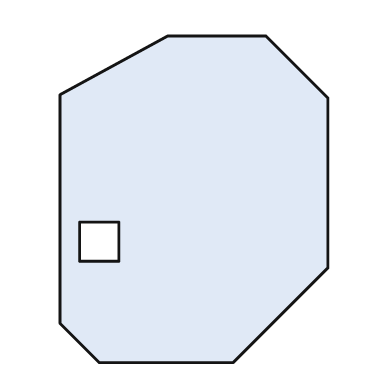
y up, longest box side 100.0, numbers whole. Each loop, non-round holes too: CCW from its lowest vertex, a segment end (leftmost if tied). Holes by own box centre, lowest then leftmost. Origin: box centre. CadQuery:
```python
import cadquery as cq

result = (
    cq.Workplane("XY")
    .moveTo(-29.0, -50.0)
    .lineTo(12.0, -50.0)
    .lineTo(41.0, -21.0)
    .lineTo(41.0, 31.0)
    .lineTo(22.0, 50.0)
    .lineTo(-8.0, 50.0)
    .lineTo(-41.0, 32.0)
    .lineTo(-41.0, -38.0)
    .close()
    .moveTo(-35.0, -19.0)
    .lineTo(-23.0, -19.0)
    .lineTo(-23.0, -7.0)
    .lineTo(-35.0, -7.0)
    .close()
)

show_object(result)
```